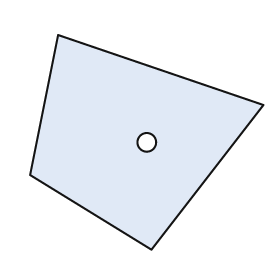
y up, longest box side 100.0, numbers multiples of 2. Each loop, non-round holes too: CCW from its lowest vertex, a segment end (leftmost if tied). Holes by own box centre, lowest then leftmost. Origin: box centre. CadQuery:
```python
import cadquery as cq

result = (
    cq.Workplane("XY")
    .moveTo(2.0, -46.0)
    .lineTo(50.0, 16.0)
    .lineTo(-38.0, 46.0)
    .lineTo(-50.0, -14.0)
    .close()
    .moveTo(0.0, 0.0)
    .circle(4.0)
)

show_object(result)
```